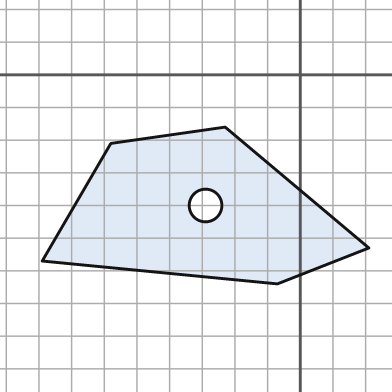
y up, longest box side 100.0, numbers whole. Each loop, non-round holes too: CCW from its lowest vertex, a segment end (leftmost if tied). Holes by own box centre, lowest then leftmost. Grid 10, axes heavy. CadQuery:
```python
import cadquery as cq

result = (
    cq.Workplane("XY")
    .moveTo(-7.0, -64.0)
    .lineTo(21.0, -53.0)
    .lineTo(-23.0, -16.0)
    .lineTo(-58.0, -21.0)
    .lineTo(-79.0, -57.0)
    .close()
    .moveTo(-29.0, -40.0)
    .circle(5.0)
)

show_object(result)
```